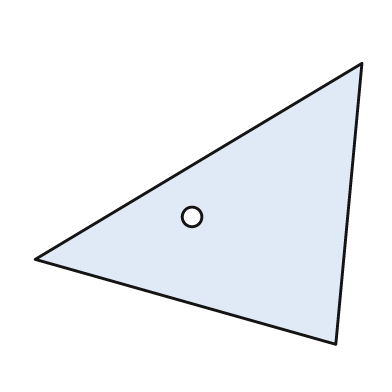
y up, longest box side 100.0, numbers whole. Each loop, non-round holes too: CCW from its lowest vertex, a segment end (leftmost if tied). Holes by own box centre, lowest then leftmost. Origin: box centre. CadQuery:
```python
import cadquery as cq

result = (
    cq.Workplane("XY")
    .moveTo(42.0, -43.0)
    .lineTo(50.0, 43.0)
    .lineTo(-50.0, -17.0)
    .close()
    .moveTo(-2.0, -4.0)
    .circle(3.0)
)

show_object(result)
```